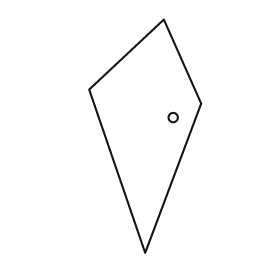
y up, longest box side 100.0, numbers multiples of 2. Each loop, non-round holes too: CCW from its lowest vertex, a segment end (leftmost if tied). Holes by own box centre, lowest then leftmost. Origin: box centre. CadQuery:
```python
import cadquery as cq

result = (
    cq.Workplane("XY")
    .moveTo(0.0, -50.0)
    .lineTo(24.0, 14.0)
    .lineTo(8.0, 50.0)
    .lineTo(-24.0, 20.0)
    .close()
    .moveTo(12.0, 8.0)
    .circle(2.0)
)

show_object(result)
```